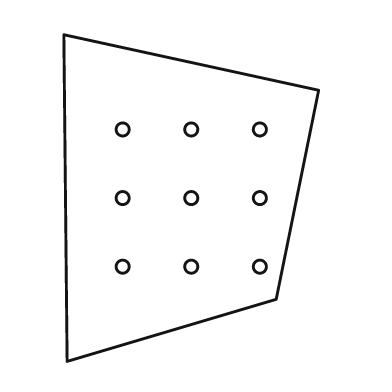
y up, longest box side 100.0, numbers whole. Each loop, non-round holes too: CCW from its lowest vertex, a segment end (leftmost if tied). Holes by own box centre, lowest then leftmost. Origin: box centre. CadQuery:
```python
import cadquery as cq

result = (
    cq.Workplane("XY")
    .moveTo(-38.0, -50.0)
    .lineTo(26.0, -31.0)
    .lineTo(39.0, 33.0)
    .lineTo(-39.0, 50.0)
    .close()
    .moveTo(-21.0, -21.0)
    .circle(2.0)
    .moveTo(0.0, -21.0)
    .circle(2.0)
    .moveTo(21.0, -21.0)
    .circle(2.0)
    .moveTo(-21.0, 0.0)
    .circle(2.0)
    .moveTo(0.0, 0.0)
    .circle(2.0)
    .moveTo(21.0, 0.0)
    .circle(2.0)
    .moveTo(-21.0, 21.0)
    .circle(2.0)
    .moveTo(0.0, 21.0)
    .circle(2.0)
    .moveTo(21.0, 21.0)
    .circle(2.0)
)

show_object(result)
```